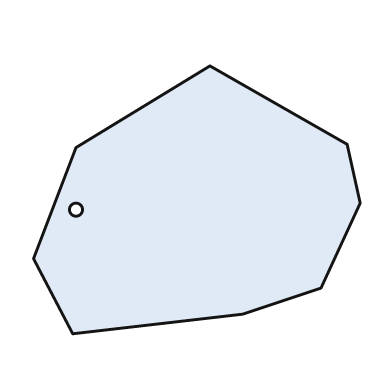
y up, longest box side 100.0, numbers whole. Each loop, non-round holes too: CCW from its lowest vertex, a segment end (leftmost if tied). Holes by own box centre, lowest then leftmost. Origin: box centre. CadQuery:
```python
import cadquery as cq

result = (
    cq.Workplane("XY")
    .moveTo(-38.0, -41.0)
    .lineTo(14.0, -35.0)
    .lineTo(38.0, -27.0)
    .lineTo(50.0, -1.0)
    .lineTo(46.0, 17.0)
    .lineTo(4.0, 41.0)
    .lineTo(-37.0, 16.0)
    .lineTo(-50.0, -18.0)
    .close()
    .moveTo(-37.0, -3.0)
    .circle(2.0)
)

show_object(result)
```